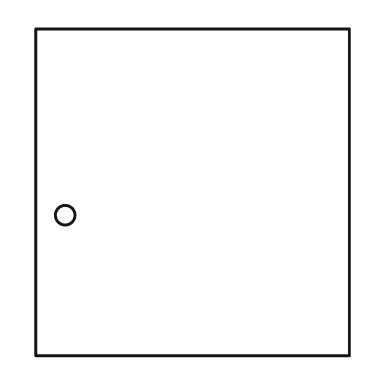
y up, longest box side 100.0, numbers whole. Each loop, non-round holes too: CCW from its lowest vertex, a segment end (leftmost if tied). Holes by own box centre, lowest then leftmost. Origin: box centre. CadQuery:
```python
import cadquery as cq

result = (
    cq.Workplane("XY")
    .moveTo(-48.0, -50.0)
    .lineTo(48.0, -50.0)
    .lineTo(48.0, 50.0)
    .lineTo(-48.0, 50.0)
    .close()
    .moveTo(-39.0, -7.0)
    .circle(3.0)
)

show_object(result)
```